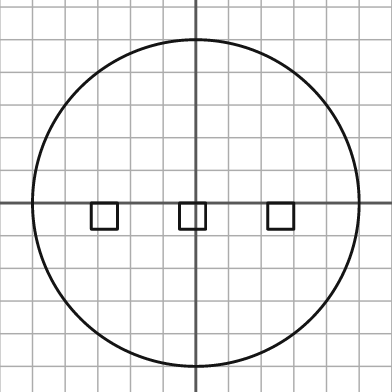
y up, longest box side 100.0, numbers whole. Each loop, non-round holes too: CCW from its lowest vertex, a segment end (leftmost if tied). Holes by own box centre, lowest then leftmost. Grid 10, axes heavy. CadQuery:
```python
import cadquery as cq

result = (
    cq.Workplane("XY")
    .moveTo(0.0, 0.0)
    .circle(50.0)
    .moveTo(-32.0, -8.0)
    .lineTo(-24.0, -8.0)
    .lineTo(-24.0, 0.0)
    .lineTo(-32.0, 0.0)
    .close()
    .moveTo(-5.0, -8.0)
    .lineTo(3.0, -8.0)
    .lineTo(3.0, 0.0)
    .lineTo(-5.0, 0.0)
    .close()
    .moveTo(22.0, -8.0)
    .lineTo(30.0, -8.0)
    .lineTo(30.0, 0.0)
    .lineTo(22.0, 0.0)
    .close()
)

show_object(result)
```